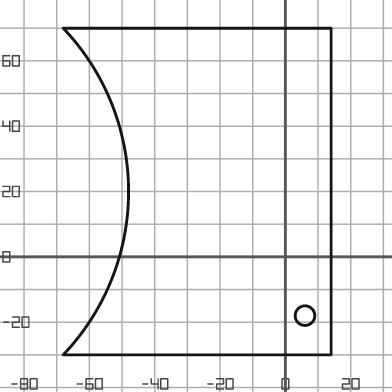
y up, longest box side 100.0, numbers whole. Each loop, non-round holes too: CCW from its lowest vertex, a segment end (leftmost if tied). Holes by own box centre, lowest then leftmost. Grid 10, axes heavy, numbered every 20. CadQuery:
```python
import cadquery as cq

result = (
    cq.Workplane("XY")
    .moveTo(-68.0, -30.0)
    .lineTo(14.0, -30.0)
    .lineTo(14.0, 70.0)
    .lineTo(-68.0, 70.0)
    .threePointArc((-48.0, 20.0), (-68.0, -30.0))
    .close()
    .moveTo(6.0, -18.0)
    .circle(3.0)
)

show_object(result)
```